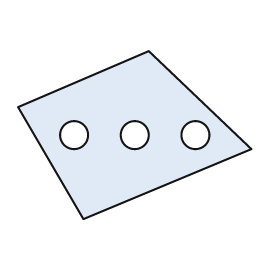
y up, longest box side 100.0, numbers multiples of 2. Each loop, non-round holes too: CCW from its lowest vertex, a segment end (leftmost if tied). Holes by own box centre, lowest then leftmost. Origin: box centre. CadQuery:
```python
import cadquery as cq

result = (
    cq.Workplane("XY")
    .moveTo(-22.0, -36.0)
    .lineTo(50.0, -6.0)
    .lineTo(6.0, 36.0)
    .lineTo(-50.0, 12.0)
    .close()
    .moveTo(-26.0, 0.0)
    .circle(6.0)
    .moveTo(0.0, 0.0)
    .circle(6.0)
    .moveTo(26.0, 0.0)
    .circle(6.0)
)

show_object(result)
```